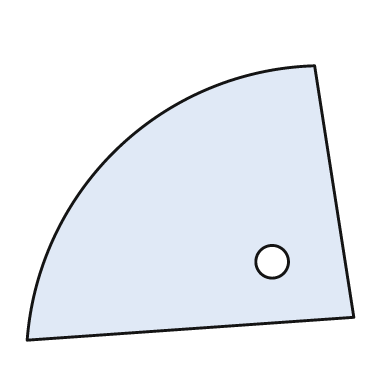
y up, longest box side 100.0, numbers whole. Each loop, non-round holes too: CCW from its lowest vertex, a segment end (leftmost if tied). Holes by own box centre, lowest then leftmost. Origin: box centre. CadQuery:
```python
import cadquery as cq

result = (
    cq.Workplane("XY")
    .moveTo(-50.0, -42.0)
    .lineTo(50.0, -35.0)
    .lineTo(38.0, 42.0)
    .threePointArc((-22.0, 17.0), (-50.0, -42.0))
    .close()
    .moveTo(25.0, -18.0)
    .circle(5.0)
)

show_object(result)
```